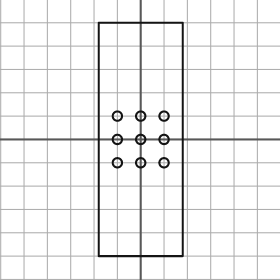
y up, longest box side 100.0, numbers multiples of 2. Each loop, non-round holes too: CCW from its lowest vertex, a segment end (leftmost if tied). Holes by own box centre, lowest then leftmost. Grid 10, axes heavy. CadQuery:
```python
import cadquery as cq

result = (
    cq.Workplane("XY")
    .moveTo(-18.0, -50.0)
    .lineTo(18.0, -50.0)
    .lineTo(18.0, 50.0)
    .lineTo(-18.0, 50.0)
    .close()
    .moveTo(-10.0, -10.0)
    .circle(2.0)
    .moveTo(0.0, -10.0)
    .circle(2.0)
    .moveTo(10.0, -10.0)
    .circle(2.0)
    .moveTo(-10.0, 0.0)
    .circle(2.0)
    .moveTo(0.0, 0.0)
    .circle(2.0)
    .moveTo(10.0, 0.0)
    .circle(2.0)
    .moveTo(-10.0, 10.0)
    .circle(2.0)
    .moveTo(0.0, 10.0)
    .circle(2.0)
    .moveTo(10.0, 10.0)
    .circle(2.0)
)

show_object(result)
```